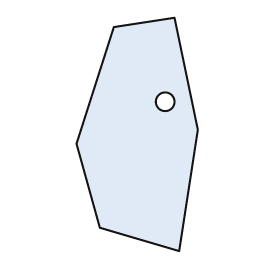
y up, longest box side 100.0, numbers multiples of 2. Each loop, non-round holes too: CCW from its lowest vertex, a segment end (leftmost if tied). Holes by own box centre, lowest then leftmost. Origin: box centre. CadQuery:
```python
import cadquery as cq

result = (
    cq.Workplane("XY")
    .moveTo(18.0, -50.0)
    .lineTo(26.0, 2.0)
    .lineTo(16.0, 50.0)
    .lineTo(-10.0, 46.0)
    .lineTo(-26.0, -4.0)
    .lineTo(-16.0, -40.0)
    .close()
    .moveTo(12.0, 14.0)
    .circle(4.0)
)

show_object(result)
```